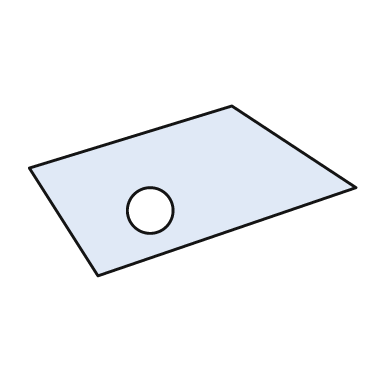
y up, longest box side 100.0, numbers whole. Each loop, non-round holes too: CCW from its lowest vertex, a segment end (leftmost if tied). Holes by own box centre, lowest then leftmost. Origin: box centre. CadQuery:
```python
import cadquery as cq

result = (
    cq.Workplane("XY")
    .moveTo(-29.0, -26.0)
    .lineTo(50.0, 1.0)
    .lineTo(12.0, 26.0)
    .lineTo(-50.0, 7.0)
    .close()
    .moveTo(-13.0, -6.0)
    .circle(7.0)
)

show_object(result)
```